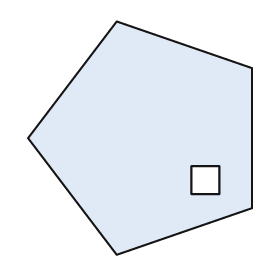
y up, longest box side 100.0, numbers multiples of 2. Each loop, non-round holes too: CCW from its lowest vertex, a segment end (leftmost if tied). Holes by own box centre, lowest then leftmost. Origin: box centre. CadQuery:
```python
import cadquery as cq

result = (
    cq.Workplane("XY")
    .moveTo(-10.0, -50.0)
    .lineTo(48.0, -30.0)
    .lineTo(48.0, 30.0)
    .lineTo(-10.0, 50.0)
    .lineTo(-48.0, 0.0)
    .close()
    .moveTo(22.0, -24.0)
    .lineTo(34.0, -24.0)
    .lineTo(34.0, -12.0)
    .lineTo(22.0, -12.0)
    .close()
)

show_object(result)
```